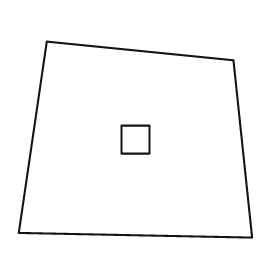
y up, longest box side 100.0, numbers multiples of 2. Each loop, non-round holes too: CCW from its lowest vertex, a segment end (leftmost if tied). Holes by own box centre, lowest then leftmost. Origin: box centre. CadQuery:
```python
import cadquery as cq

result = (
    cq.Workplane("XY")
    .moveTo(50.0, -42.0)
    .lineTo(42.0, 34.0)
    .lineTo(-38.0, 42.0)
    .lineTo(-50.0, -40.0)
    .close()
    .moveTo(-6.0, -6.0)
    .lineTo(6.0, -6.0)
    .lineTo(6.0, 6.0)
    .lineTo(-6.0, 6.0)
    .close()
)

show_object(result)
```